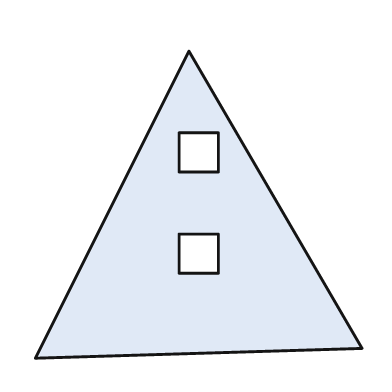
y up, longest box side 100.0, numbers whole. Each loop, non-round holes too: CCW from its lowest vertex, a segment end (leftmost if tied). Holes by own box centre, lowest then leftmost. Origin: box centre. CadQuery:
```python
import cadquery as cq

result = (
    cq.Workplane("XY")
    .moveTo(-50.0, -47.0)
    .lineTo(50.0, -44.0)
    .lineTo(-3.0, 47.0)
    .close()
    .moveTo(-6.0, -21.0)
    .lineTo(6.0, -21.0)
    .lineTo(6.0, -9.0)
    .lineTo(-6.0, -9.0)
    .close()
    .moveTo(-6.0, 10.0)
    .lineTo(6.0, 10.0)
    .lineTo(6.0, 22.0)
    .lineTo(-6.0, 22.0)
    .close()
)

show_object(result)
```